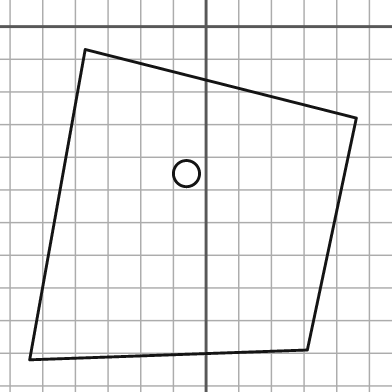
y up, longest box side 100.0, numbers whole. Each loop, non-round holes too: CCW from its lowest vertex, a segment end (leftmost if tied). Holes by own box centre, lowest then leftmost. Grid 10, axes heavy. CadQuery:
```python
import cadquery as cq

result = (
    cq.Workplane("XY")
    .moveTo(-54.0, -102.0)
    .lineTo(31.0, -99.0)
    .lineTo(46.0, -28.0)
    .lineTo(-37.0, -7.0)
    .close()
    .moveTo(-6.0, -45.0)
    .circle(4.0)
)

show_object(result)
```